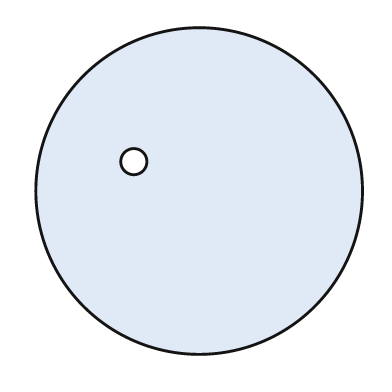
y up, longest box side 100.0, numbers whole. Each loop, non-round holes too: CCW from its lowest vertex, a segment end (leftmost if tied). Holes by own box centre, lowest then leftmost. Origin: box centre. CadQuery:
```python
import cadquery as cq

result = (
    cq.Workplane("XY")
    .moveTo(0.0, 0.0)
    .circle(50.0)
    .moveTo(-20.0, 9.0)
    .circle(4.0)
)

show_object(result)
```